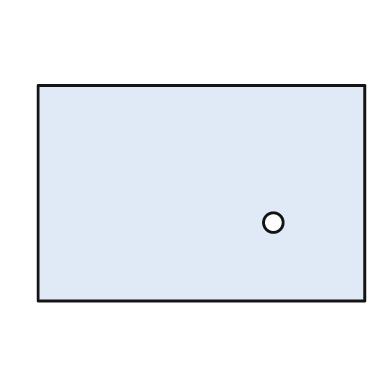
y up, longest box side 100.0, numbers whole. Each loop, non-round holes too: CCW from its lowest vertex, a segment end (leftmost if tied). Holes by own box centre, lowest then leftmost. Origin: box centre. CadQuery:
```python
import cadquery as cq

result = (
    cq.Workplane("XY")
    .moveTo(-50.0, -33.0)
    .lineTo(50.0, -33.0)
    .lineTo(50.0, 33.0)
    .lineTo(-50.0, 33.0)
    .close()
    .moveTo(22.0, -9.0)
    .circle(3.0)
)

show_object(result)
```